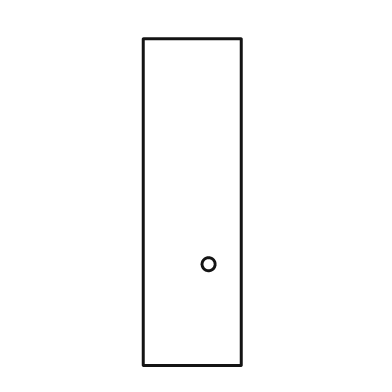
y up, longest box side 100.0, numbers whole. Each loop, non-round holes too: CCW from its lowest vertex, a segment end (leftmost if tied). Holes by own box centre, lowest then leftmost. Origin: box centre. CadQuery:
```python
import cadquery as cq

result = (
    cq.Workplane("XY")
    .moveTo(-15.0, -50.0)
    .lineTo(15.0, -50.0)
    .lineTo(15.0, 50.0)
    .lineTo(-15.0, 50.0)
    .close()
    .moveTo(5.0, -19.0)
    .circle(2.0)
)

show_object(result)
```